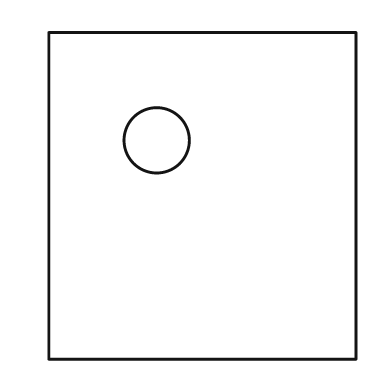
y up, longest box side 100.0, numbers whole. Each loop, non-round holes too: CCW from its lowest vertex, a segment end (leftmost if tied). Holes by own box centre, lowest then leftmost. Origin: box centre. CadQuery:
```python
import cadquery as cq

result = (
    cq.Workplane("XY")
    .moveTo(-47.0, -50.0)
    .lineTo(47.0, -50.0)
    .lineTo(47.0, 50.0)
    .lineTo(-47.0, 50.0)
    .close()
    .moveTo(-14.0, 17.0)
    .circle(10.0)
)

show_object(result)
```